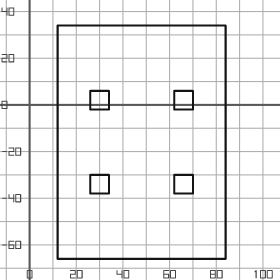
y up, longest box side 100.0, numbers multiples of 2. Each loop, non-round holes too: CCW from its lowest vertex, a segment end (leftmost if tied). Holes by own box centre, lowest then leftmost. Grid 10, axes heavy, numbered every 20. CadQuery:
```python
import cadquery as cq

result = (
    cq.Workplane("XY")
    .moveTo(12.0, -66.0)
    .lineTo(84.0, -66.0)
    .lineTo(84.0, 34.0)
    .lineTo(12.0, 34.0)
    .close()
    .moveTo(26.0, -38.0)
    .lineTo(34.0, -38.0)
    .lineTo(34.0, -30.0)
    .lineTo(26.0, -30.0)
    .close()
    .moveTo(62.0, -38.0)
    .lineTo(70.0, -38.0)
    .lineTo(70.0, -30.0)
    .lineTo(62.0, -30.0)
    .close()
    .moveTo(26.0, -2.0)
    .lineTo(34.0, -2.0)
    .lineTo(34.0, 6.0)
    .lineTo(26.0, 6.0)
    .close()
    .moveTo(62.0, -2.0)
    .lineTo(70.0, -2.0)
    .lineTo(70.0, 6.0)
    .lineTo(62.0, 6.0)
    .close()
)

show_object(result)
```